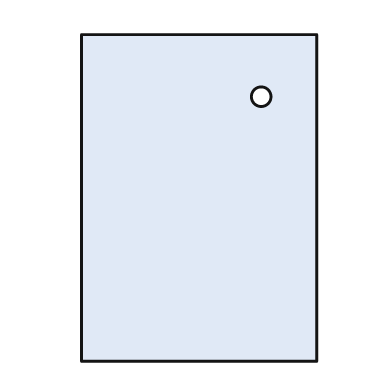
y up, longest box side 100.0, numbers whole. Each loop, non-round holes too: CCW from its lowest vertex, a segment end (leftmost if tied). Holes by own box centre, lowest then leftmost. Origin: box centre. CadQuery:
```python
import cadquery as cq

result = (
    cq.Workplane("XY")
    .moveTo(-36.0, -50.0)
    .lineTo(36.0, -50.0)
    .lineTo(36.0, 50.0)
    .lineTo(-36.0, 50.0)
    .close()
    .moveTo(19.0, 31.0)
    .circle(3.0)
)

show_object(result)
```